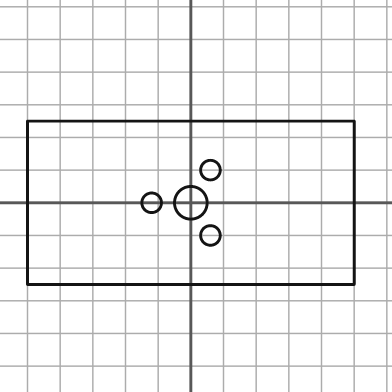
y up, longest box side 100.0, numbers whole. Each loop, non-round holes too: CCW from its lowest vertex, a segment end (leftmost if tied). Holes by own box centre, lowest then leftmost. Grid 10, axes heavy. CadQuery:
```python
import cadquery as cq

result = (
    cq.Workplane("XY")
    .moveTo(-50.0, -25.0)
    .lineTo(50.0, -25.0)
    .lineTo(50.0, 25.0)
    .lineTo(-50.0, 25.0)
    .close()
    .moveTo(6.0, -10.0)
    .circle(3.0)
    .moveTo(-12.0, 0.0)
    .circle(3.0)
    .moveTo(0.0, 0.0)
    .circle(5.0)
    .moveTo(6.0, 10.0)
    .circle(3.0)
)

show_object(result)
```